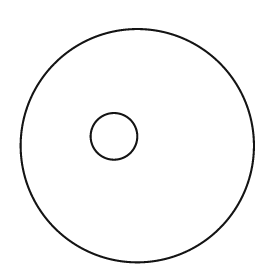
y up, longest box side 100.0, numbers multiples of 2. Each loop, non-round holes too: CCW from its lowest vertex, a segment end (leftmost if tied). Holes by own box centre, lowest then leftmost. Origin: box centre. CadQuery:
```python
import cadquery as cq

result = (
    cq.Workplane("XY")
    .moveTo(0.0, 0.0)
    .circle(50.0)
    .moveTo(-10.0, 4.0)
    .circle(10.0)
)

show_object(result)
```